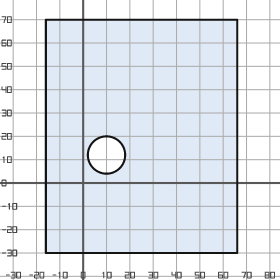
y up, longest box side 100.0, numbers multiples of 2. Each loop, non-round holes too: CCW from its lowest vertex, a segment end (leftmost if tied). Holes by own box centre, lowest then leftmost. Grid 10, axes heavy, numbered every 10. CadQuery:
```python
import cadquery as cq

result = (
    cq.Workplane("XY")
    .moveTo(-16.0, -30.0)
    .lineTo(66.0, -30.0)
    .lineTo(66.0, 70.0)
    .lineTo(-16.0, 70.0)
    .close()
    .moveTo(10.0, 12.0)
    .circle(8.0)
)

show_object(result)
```